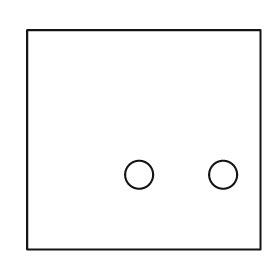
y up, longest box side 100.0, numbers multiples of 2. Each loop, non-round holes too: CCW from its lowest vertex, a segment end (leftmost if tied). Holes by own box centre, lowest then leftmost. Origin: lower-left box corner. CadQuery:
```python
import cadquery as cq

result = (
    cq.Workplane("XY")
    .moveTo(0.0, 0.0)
    .lineTo(100.0, 0.0)
    .lineTo(100.0, 94.0)
    .lineTo(0.0, 94.0)
    .close()
    .moveTo(48.0, 32.0)
    .circle(6.0)
    .moveTo(84.0, 32.0)
    .circle(6.0)
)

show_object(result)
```